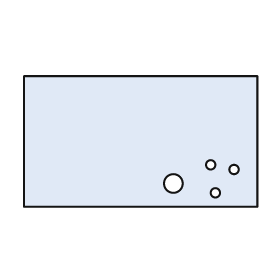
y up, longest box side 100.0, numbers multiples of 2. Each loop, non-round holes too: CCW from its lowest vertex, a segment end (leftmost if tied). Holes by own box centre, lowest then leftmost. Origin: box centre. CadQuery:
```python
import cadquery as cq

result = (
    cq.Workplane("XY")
    .moveTo(-50.0, -28.0)
    .lineTo(50.0, -28.0)
    .lineTo(50.0, 28.0)
    .lineTo(-50.0, 28.0)
    .close()
    .moveTo(32.0, -22.0)
    .circle(2.0)
    .moveTo(14.0, -18.0)
    .circle(4.0)
    .moveTo(40.0, -12.0)
    .circle(2.0)
    .moveTo(30.0, -10.0)
    .circle(2.0)
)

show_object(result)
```